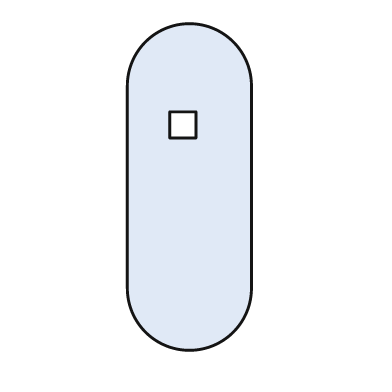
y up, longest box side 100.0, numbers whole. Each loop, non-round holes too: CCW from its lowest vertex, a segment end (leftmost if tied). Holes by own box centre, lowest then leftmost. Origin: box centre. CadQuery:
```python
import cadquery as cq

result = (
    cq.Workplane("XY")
    .moveTo(-19.0, -31.0)
    .threePointArc((0.0, -50.0), (19.0, -31.0))
    .lineTo(19.0, 31.0)
    .threePointArc((0.0, 50.0), (-19.0, 31.0))
    .close()
    .moveTo(-6.0, 15.0)
    .lineTo(2.0, 15.0)
    .lineTo(2.0, 23.0)
    .lineTo(-6.0, 23.0)
    .close()
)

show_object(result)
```